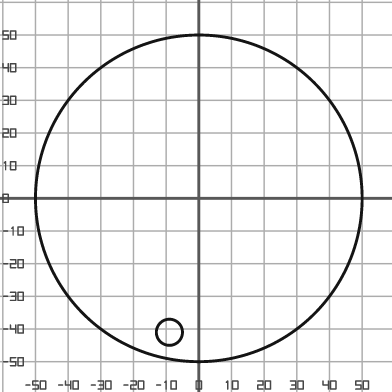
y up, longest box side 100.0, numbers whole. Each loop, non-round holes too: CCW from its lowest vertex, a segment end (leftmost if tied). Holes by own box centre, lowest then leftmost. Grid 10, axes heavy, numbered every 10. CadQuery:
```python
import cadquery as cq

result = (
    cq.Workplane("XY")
    .moveTo(0.0, 0.0)
    .circle(50.0)
    .moveTo(-9.0, -41.0)
    .circle(4.0)
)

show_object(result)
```